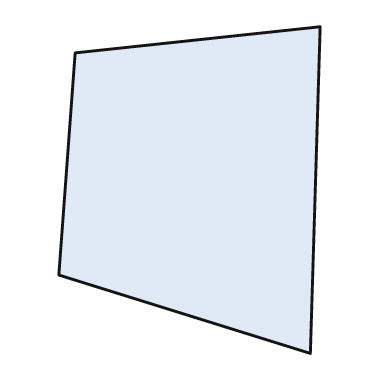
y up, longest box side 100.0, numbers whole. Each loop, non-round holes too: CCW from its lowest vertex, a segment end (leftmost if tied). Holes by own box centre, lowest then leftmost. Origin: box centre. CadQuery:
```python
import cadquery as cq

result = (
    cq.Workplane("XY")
    .moveTo(37.0, -50.0)
    .lineTo(40.0, 50.0)
    .lineTo(-35.0, 42.0)
    .lineTo(-40.0, -26.0)
    .close()
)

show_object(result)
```